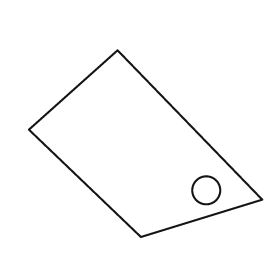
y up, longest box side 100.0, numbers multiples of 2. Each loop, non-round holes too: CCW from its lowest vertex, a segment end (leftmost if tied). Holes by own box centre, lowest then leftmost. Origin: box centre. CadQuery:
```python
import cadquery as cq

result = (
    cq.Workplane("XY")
    .moveTo(-2.0, -40.0)
    .lineTo(50.0, -24.0)
    .lineTo(-12.0, 40.0)
    .lineTo(-50.0, 6.0)
    .close()
    .moveTo(26.0, -20.0)
    .circle(6.0)
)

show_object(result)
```